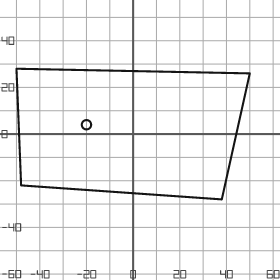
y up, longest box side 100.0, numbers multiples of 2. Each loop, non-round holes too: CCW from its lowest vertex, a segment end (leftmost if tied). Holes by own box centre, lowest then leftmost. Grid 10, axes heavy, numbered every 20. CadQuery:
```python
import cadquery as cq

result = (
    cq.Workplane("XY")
    .moveTo(38.0, -28.0)
    .lineTo(50.0, 26.0)
    .lineTo(-50.0, 28.0)
    .lineTo(-48.0, -22.0)
    .close()
    .moveTo(-20.0, 4.0)
    .circle(2.0)
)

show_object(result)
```